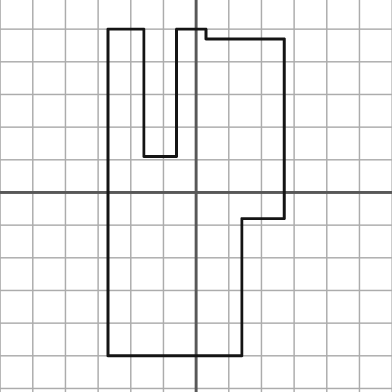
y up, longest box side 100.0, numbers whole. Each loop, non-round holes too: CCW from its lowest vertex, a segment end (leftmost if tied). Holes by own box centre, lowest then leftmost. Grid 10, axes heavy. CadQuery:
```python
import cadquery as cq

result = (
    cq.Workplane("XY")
    .moveTo(-27.0, -50.0)
    .lineTo(14.0, -50.0)
    .lineTo(14.0, -8.0)
    .lineTo(27.0, -8.0)
    .lineTo(27.0, 47.0)
    .lineTo(3.0, 47.0)
    .lineTo(3.0, 50.0)
    .lineTo(-6.0, 50.0)
    .lineTo(-6.0, 11.0)
    .lineTo(-16.0, 11.0)
    .lineTo(-16.0, 50.0)
    .lineTo(-27.0, 50.0)
    .close()
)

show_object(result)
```